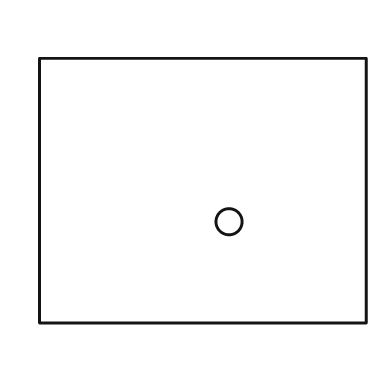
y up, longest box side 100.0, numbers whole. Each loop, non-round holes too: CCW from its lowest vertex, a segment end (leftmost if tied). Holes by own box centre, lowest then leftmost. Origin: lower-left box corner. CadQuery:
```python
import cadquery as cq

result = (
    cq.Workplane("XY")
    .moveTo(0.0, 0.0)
    .lineTo(100.0, 0.0)
    .lineTo(100.0, 81.0)
    .lineTo(0.0, 81.0)
    .close()
    .moveTo(58.0, 31.0)
    .circle(4.0)
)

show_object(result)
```